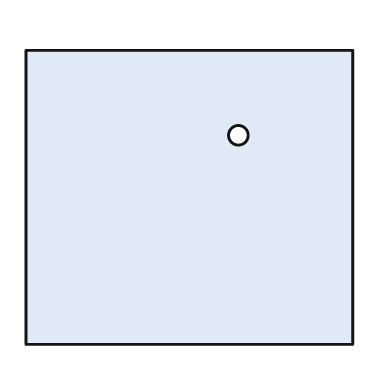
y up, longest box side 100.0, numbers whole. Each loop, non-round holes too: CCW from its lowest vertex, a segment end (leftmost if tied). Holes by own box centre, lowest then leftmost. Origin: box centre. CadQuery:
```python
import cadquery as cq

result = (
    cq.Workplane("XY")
    .moveTo(-50.0, -45.0)
    .lineTo(50.0, -45.0)
    .lineTo(50.0, 45.0)
    .lineTo(-50.0, 45.0)
    .close()
    .moveTo(15.0, 19.0)
    .circle(3.0)
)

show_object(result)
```